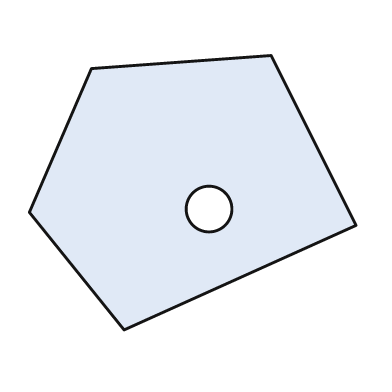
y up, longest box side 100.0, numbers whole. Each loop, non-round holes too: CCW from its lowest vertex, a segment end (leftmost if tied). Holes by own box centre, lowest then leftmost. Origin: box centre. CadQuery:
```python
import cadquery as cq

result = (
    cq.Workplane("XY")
    .moveTo(-21.0, -42.0)
    .lineTo(50.0, -10.0)
    .lineTo(24.0, 42.0)
    .lineTo(-31.0, 38.0)
    .lineTo(-50.0, -6.0)
    .close()
    .moveTo(5.0, -5.0)
    .circle(7.0)
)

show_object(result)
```